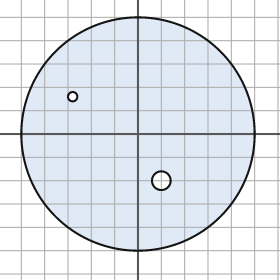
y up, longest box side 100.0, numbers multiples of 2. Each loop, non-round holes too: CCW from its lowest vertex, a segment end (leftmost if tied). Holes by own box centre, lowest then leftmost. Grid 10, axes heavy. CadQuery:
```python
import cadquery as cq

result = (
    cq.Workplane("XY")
    .moveTo(0.0, 0.0)
    .circle(50.0)
    .moveTo(10.0, -20.0)
    .circle(4.0)
    .moveTo(-28.0, 16.0)
    .circle(2.0)
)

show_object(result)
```